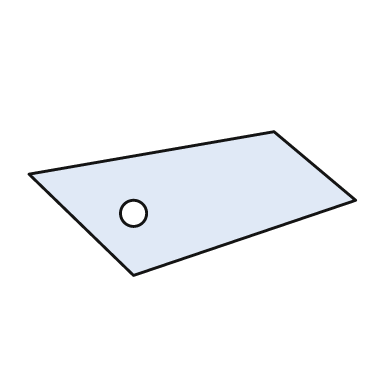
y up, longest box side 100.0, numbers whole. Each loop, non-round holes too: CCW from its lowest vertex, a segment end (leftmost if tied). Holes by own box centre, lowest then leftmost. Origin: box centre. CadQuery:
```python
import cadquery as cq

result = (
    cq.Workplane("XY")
    .moveTo(-18.0, -22.0)
    .lineTo(50.0, 1.0)
    .lineTo(25.0, 22.0)
    .lineTo(-50.0, 9.0)
    .close()
    .moveTo(-18.0, -3.0)
    .circle(4.0)
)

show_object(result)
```